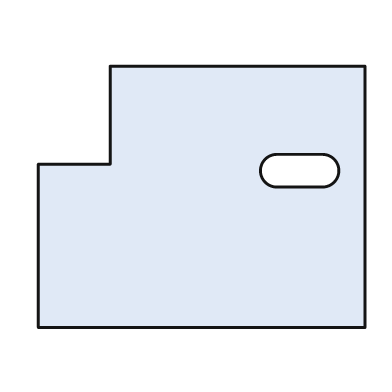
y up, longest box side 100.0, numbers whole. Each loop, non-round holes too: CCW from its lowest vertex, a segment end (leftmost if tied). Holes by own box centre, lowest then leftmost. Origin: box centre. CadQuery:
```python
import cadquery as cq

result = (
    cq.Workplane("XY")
    .moveTo(-50.0, -40.0)
    .lineTo(50.0, -40.0)
    .lineTo(50.0, 40.0)
    .lineTo(-28.0, 40.0)
    .lineTo(-28.0, 10.0)
    .lineTo(-50.0, 10.0)
    .close()
    .moveTo(23.0, 3.0)
    .lineTo(37.0, 3.0)
    .threePointArc((42.0, 8.0), (37.0, 13.0))
    .lineTo(23.0, 13.0)
    .threePointArc((18.0, 8.0), (23.0, 3.0))
    .close()
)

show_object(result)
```